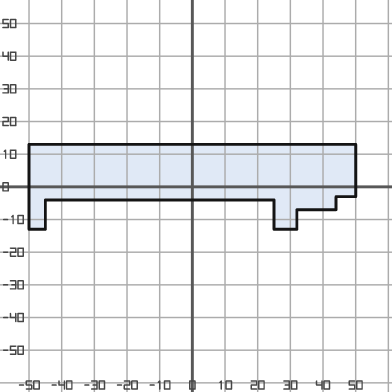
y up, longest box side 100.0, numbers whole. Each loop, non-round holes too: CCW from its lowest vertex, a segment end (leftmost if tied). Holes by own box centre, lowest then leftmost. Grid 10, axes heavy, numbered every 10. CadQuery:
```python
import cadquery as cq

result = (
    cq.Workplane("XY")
    .moveTo(-50.0, -13.0)
    .lineTo(-45.0, -13.0)
    .lineTo(-45.0, -4.0)
    .lineTo(25.0, -4.0)
    .lineTo(25.0, -13.0)
    .lineTo(32.0, -13.0)
    .lineTo(32.0, -7.0)
    .lineTo(44.0, -7.0)
    .lineTo(44.0, -3.0)
    .lineTo(50.0, -3.0)
    .lineTo(50.0, 13.0)
    .lineTo(-50.0, 13.0)
    .close()
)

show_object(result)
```